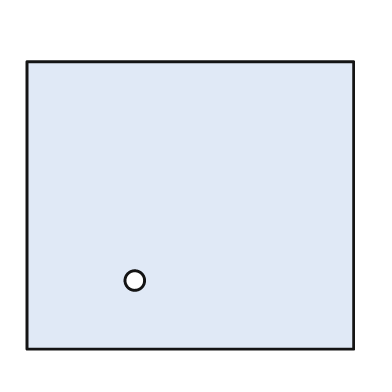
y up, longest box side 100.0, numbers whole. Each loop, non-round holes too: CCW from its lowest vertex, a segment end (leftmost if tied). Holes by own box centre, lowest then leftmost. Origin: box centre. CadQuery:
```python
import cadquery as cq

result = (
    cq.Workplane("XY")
    .moveTo(-50.0, -44.0)
    .lineTo(50.0, -44.0)
    .lineTo(50.0, 44.0)
    .lineTo(-50.0, 44.0)
    .close()
    .moveTo(-17.0, -23.0)
    .circle(3.0)
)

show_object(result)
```